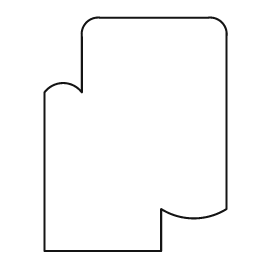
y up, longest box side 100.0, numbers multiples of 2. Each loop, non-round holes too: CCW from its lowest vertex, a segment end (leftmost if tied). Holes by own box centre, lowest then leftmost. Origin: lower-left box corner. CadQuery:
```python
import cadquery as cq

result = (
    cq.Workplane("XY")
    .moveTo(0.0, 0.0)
    .lineTo(50.0, 0.0)
    .lineTo(50.0, 18.0)
    .threePointArc((64.0, 14.0), (78.0, 18.0))
    .lineTo(78.0, 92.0)
    .threePointArc((76.0, 98.0), (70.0, 100.0))
    .lineTo(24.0, 100.0)
    .threePointArc((18.0, 98.0), (16.0, 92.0))
    .lineTo(16.0, 68.0)
    .threePointArc((8.0, 72.0), (0.0, 68.0))
    .close()
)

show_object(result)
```